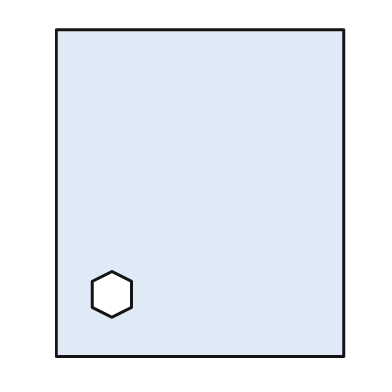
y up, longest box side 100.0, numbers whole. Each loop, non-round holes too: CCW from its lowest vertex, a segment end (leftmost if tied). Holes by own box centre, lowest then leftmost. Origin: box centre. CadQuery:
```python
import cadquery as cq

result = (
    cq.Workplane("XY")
    .moveTo(-44.0, -50.0)
    .lineTo(44.0, -50.0)
    .lineTo(44.0, 50.0)
    .lineTo(-44.0, 50.0)
    .close()
    .moveTo(-27.0, -38.0)
    .lineTo(-21.0, -35.0)
    .lineTo(-21.0, -27.0)
    .lineTo(-27.0, -24.0)
    .lineTo(-33.0, -27.0)
    .lineTo(-33.0, -35.0)
    .close()
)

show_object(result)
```